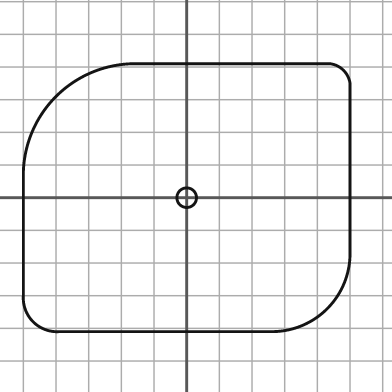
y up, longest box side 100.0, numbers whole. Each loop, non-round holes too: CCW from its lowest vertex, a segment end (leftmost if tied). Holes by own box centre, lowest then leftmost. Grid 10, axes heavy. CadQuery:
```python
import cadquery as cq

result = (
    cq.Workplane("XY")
    .moveTo(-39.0, -41.0)
    .lineTo(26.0, -41.0)
    .threePointArc((43.0, -34.0), (50.0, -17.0))
    .lineTo(50.0, 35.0)
    .threePointArc((48.0, 39.0), (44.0, 41.0))
    .lineTo(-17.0, 41.0)
    .threePointArc((-40.0, 31.0), (-50.0, 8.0))
    .lineTo(-50.0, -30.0)
    .threePointArc((-47.0, -38.0), (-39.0, -41.0))
    .close()
    .moveTo(0.0, 0.0)
    .circle(3.0)
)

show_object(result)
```